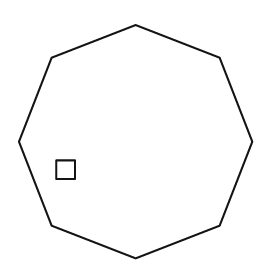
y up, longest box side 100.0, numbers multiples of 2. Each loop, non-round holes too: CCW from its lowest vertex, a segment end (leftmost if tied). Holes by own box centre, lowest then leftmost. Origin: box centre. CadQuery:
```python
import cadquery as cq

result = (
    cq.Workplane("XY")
    .moveTo(0.0, -50.0)
    .lineTo(36.0, -36.0)
    .lineTo(50.0, 0.0)
    .lineTo(36.0, 36.0)
    .lineTo(0.0, 50.0)
    .lineTo(-36.0, 36.0)
    .lineTo(-50.0, 0.0)
    .lineTo(-36.0, -36.0)
    .close()
    .moveTo(-34.0, -16.0)
    .lineTo(-26.0, -16.0)
    .lineTo(-26.0, -8.0)
    .lineTo(-34.0, -8.0)
    .close()
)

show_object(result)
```